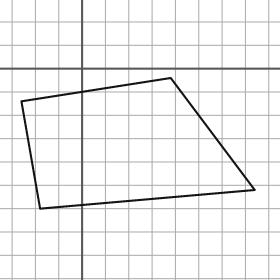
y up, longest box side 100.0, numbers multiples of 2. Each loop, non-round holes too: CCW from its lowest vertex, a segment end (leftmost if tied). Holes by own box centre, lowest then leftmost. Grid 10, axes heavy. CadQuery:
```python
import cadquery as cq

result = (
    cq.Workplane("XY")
    .moveTo(-18.0, -60.0)
    .lineTo(74.0, -52.0)
    .lineTo(38.0, -4.0)
    .lineTo(-26.0, -14.0)
    .close()
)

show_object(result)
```